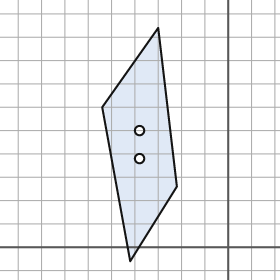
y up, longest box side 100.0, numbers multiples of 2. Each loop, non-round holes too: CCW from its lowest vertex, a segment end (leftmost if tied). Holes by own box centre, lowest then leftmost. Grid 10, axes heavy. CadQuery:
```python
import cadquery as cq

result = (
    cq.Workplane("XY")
    .moveTo(-42.0, -6.0)
    .lineTo(-22.0, 26.0)
    .lineTo(-30.0, 94.0)
    .lineTo(-54.0, 60.0)
    .close()
    .moveTo(-38.0, 38.0)
    .circle(2.0)
    .moveTo(-38.0, 50.0)
    .circle(2.0)
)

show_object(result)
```